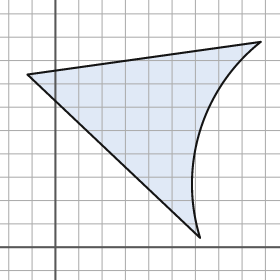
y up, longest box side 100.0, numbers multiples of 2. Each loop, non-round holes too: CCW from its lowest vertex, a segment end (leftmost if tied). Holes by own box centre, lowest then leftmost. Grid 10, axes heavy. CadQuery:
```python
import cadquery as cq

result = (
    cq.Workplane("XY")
    .moveTo(62.0, 4.0)
    .threePointArc((62.0, 50.0), (88.0, 88.0))
    .lineTo(-12.0, 74.0)
    .close()
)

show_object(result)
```